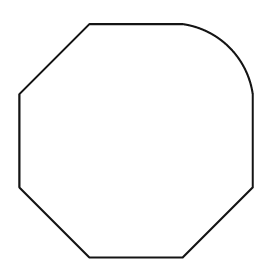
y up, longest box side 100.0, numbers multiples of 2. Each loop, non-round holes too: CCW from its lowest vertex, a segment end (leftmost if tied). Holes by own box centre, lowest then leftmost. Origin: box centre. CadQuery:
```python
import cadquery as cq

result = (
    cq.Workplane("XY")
    .moveTo(-20.0, -50.0)
    .lineTo(20.0, -50.0)
    .lineTo(50.0, -20.0)
    .lineTo(50.0, 20.0)
    .threePointArc((40.0, 40.0), (20.0, 50.0))
    .lineTo(-20.0, 50.0)
    .lineTo(-50.0, 20.0)
    .lineTo(-50.0, -20.0)
    .close()
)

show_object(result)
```